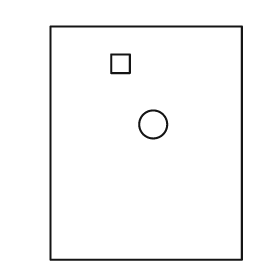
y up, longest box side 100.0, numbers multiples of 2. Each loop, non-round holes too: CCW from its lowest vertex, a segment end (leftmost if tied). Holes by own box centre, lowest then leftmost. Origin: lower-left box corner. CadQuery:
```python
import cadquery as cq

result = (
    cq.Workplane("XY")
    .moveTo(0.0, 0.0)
    .lineTo(82.0, 0.0)
    .lineTo(82.0, 100.0)
    .lineTo(0.0, 100.0)
    .close()
    .moveTo(44.0, 58.0)
    .circle(6.0)
    .moveTo(26.0, 80.0)
    .lineTo(34.0, 80.0)
    .lineTo(34.0, 88.0)
    .lineTo(26.0, 88.0)
    .close()
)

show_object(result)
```